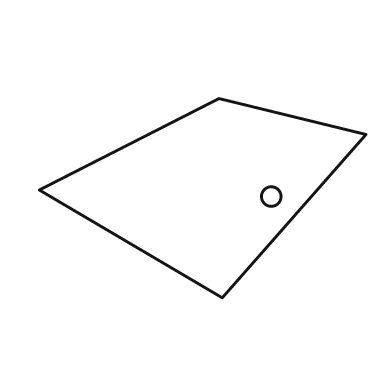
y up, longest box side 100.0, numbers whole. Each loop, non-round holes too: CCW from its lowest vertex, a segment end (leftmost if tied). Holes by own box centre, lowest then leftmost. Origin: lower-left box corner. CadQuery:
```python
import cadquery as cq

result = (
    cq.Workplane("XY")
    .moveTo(56.0, 0.0)
    .lineTo(100.0, 50.0)
    .lineTo(55.0, 61.0)
    .lineTo(0.0, 33.0)
    .close()
    .moveTo(71.0, 31.0)
    .circle(3.0)
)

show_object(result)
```